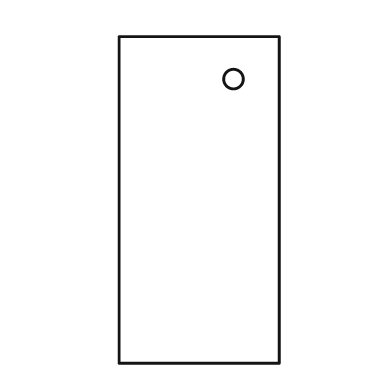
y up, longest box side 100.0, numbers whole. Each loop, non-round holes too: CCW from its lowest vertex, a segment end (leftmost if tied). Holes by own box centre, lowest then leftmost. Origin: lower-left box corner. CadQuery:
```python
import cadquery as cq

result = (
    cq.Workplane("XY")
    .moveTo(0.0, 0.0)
    .lineTo(49.0, 0.0)
    .lineTo(49.0, 100.0)
    .lineTo(0.0, 100.0)
    .close()
    .moveTo(35.0, 87.0)
    .circle(3.0)
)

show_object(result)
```